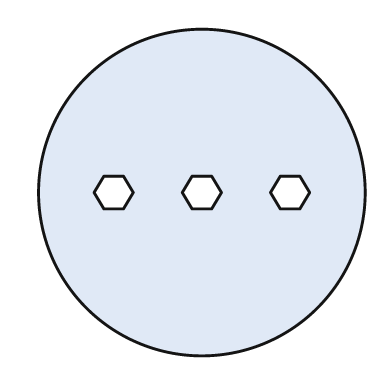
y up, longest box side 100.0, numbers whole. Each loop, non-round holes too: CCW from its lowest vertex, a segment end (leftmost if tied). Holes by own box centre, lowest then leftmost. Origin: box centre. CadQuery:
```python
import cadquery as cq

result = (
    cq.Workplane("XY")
    .moveTo(0.0, 0.0)
    .circle(50.0)
    .moveTo(-30.0, -5.0)
    .lineTo(-24.0, -5.0)
    .lineTo(-21.0, 0.0)
    .lineTo(-24.0, 5.0)
    .lineTo(-30.0, 5.0)
    .lineTo(-33.0, 0.0)
    .close()
    .moveTo(-3.0, -5.0)
    .lineTo(3.0, -5.0)
    .lineTo(6.0, 0.0)
    .lineTo(3.0, 5.0)
    .lineTo(-3.0, 5.0)
    .lineTo(-6.0, 0.0)
    .close()
    .moveTo(24.0, -5.0)
    .lineTo(30.0, -5.0)
    .lineTo(33.0, 0.0)
    .lineTo(30.0, 5.0)
    .lineTo(24.0, 5.0)
    .lineTo(21.0, 0.0)
    .close()
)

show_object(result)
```